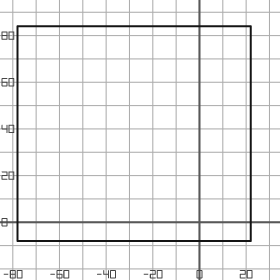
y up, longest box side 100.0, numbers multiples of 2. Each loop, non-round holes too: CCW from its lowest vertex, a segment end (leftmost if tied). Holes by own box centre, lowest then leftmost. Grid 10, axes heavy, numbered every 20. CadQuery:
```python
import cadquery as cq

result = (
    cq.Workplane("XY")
    .moveTo(-78.0, -8.0)
    .lineTo(22.0, -8.0)
    .lineTo(22.0, 84.0)
    .lineTo(-78.0, 84.0)
    .close()
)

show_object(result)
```